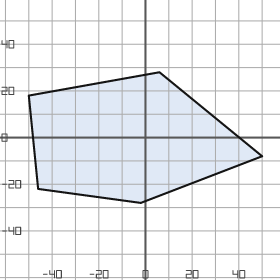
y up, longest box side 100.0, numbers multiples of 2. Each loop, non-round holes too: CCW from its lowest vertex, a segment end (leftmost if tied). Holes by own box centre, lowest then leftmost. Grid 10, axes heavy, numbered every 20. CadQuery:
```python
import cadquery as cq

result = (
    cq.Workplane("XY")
    .moveTo(-2.0, -28.0)
    .lineTo(50.0, -8.0)
    .lineTo(6.0, 28.0)
    .lineTo(-50.0, 18.0)
    .lineTo(-46.0, -22.0)
    .close()
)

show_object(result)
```